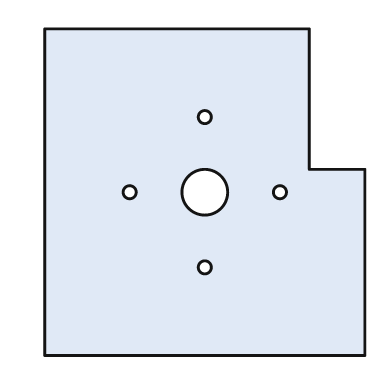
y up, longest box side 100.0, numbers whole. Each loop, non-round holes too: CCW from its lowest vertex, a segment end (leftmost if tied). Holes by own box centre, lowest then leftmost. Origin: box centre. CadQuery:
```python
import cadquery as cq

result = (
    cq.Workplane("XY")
    .moveTo(-49.0, -50.0)
    .lineTo(49.0, -50.0)
    .lineTo(49.0, 7.0)
    .lineTo(32.0, 7.0)
    .lineTo(32.0, 50.0)
    .lineTo(-49.0, 50.0)
    .close()
    .moveTo(0.0, -23.0)
    .circle(2.0)
    .moveTo(-23.0, 0.0)
    .circle(2.0)
    .moveTo(0.0, 0.0)
    .circle(7.0)
    .moveTo(23.0, 0.0)
    .circle(2.0)
    .moveTo(0.0, 23.0)
    .circle(2.0)
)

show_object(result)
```